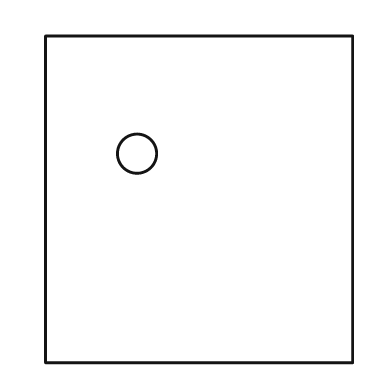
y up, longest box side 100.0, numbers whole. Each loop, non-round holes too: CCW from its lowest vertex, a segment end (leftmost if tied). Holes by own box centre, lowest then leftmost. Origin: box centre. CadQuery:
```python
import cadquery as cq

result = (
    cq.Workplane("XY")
    .moveTo(-47.0, -50.0)
    .lineTo(47.0, -50.0)
    .lineTo(47.0, 50.0)
    .lineTo(-47.0, 50.0)
    .close()
    .moveTo(-19.0, 14.0)
    .circle(6.0)
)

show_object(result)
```